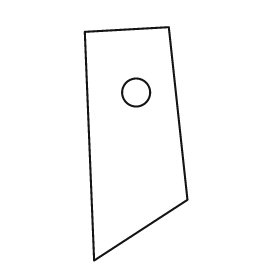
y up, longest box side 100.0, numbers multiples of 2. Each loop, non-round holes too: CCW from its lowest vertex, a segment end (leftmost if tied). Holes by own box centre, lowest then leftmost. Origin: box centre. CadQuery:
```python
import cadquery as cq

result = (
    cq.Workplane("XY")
    .moveTo(-18.0, -50.0)
    .lineTo(22.0, -24.0)
    .lineTo(14.0, 50.0)
    .lineTo(-22.0, 48.0)
    .close()
    .moveTo(0.0, 22.0)
    .circle(6.0)
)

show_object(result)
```